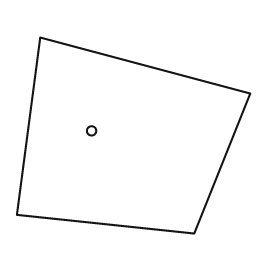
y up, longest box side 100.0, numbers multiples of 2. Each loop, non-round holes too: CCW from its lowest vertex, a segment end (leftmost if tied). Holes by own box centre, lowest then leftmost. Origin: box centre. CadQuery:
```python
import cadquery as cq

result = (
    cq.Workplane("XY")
    .moveTo(26.0, -42.0)
    .lineTo(50.0, 18.0)
    .lineTo(-40.0, 42.0)
    .lineTo(-50.0, -34.0)
    .close()
    .moveTo(-18.0, 2.0)
    .circle(2.0)
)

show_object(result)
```